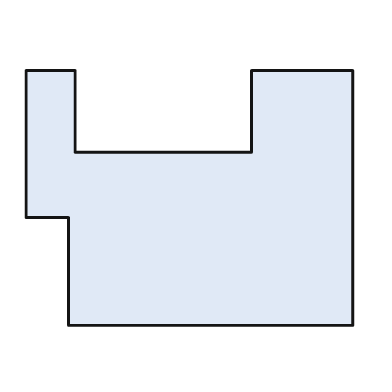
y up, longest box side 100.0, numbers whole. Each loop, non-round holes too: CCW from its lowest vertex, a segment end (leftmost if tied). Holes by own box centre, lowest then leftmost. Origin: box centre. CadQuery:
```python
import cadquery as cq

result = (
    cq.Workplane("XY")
    .moveTo(-37.0, -39.0)
    .lineTo(50.0, -39.0)
    .lineTo(50.0, 39.0)
    .lineTo(19.0, 39.0)
    .lineTo(19.0, 14.0)
    .lineTo(-35.0, 14.0)
    .lineTo(-35.0, 39.0)
    .lineTo(-50.0, 39.0)
    .lineTo(-50.0, -6.0)
    .lineTo(-37.0, -6.0)
    .close()
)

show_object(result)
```